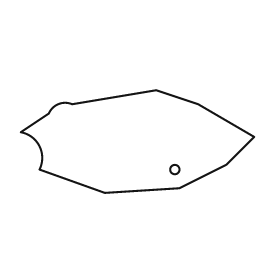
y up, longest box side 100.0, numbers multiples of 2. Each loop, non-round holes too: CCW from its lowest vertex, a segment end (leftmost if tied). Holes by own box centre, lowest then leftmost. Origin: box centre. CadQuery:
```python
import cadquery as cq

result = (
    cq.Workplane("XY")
    .moveTo(-14.0, -22.0)
    .lineTo(18.0, -20.0)
    .lineTo(38.0, -10.0)
    .lineTo(50.0, 2.0)
    .lineTo(26.0, 16.0)
    .lineTo(8.0, 22.0)
    .lineTo(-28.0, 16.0)
    .threePointArc((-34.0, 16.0), (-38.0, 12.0))
    .lineTo(-50.0, 4.0)
    .threePointArc((-42.0, -2.0), (-42.0, -12.0))
    .close()
    .moveTo(16.0, -12.0)
    .circle(2.0)
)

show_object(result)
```